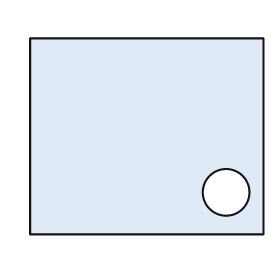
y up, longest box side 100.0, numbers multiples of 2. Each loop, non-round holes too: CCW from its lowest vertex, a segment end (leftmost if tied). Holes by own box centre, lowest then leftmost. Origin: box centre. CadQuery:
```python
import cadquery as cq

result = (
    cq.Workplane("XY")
    .moveTo(-50.0, -42.0)
    .lineTo(50.0, -42.0)
    .lineTo(50.0, 42.0)
    .lineTo(-50.0, 42.0)
    .close()
    .moveTo(34.0, -24.0)
    .circle(10.0)
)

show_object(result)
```